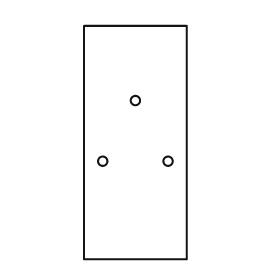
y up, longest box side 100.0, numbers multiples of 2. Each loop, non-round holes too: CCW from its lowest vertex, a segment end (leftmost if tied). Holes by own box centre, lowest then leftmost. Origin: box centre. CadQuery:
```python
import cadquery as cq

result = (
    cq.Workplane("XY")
    .moveTo(-22.0, -50.0)
    .lineTo(22.0, -50.0)
    .lineTo(22.0, 50.0)
    .lineTo(-22.0, 50.0)
    .close()
    .moveTo(-14.0, -8.0)
    .circle(2.0)
    .moveTo(14.0, -8.0)
    .circle(2.0)
    .moveTo(0.0, 18.0)
    .circle(2.0)
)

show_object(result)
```